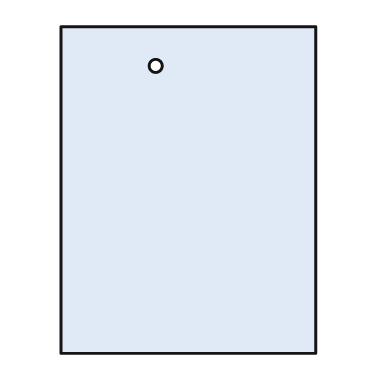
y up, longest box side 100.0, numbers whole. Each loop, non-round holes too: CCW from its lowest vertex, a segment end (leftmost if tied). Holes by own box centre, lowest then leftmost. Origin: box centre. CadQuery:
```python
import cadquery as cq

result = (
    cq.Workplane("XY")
    .moveTo(-39.0, -50.0)
    .lineTo(39.0, -50.0)
    .lineTo(39.0, 50.0)
    .lineTo(-39.0, 50.0)
    .close()
    .moveTo(-10.0, 38.0)
    .circle(2.0)
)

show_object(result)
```